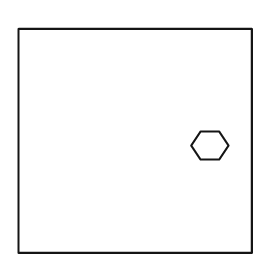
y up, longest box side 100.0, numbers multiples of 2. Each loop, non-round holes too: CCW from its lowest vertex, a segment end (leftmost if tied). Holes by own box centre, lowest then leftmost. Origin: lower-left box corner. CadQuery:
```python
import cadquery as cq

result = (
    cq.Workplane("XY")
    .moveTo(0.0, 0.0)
    .lineTo(100.0, 0.0)
    .lineTo(100.0, 96.0)
    .lineTo(0.0, 96.0)
    .close()
    .moveTo(78.0, 40.0)
    .lineTo(86.0, 40.0)
    .lineTo(90.0, 46.0)
    .lineTo(86.0, 52.0)
    .lineTo(78.0, 52.0)
    .lineTo(74.0, 46.0)
    .close()
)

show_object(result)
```